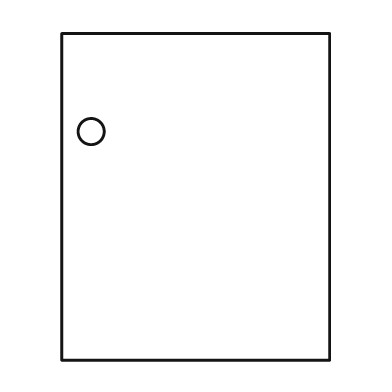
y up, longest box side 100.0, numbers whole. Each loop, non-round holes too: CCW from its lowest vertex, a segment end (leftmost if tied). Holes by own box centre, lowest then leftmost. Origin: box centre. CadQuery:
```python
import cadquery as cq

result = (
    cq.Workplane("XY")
    .moveTo(-41.0, -50.0)
    .lineTo(41.0, -50.0)
    .lineTo(41.0, 50.0)
    .lineTo(-41.0, 50.0)
    .close()
    .moveTo(-32.0, 20.0)
    .circle(4.0)
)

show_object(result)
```